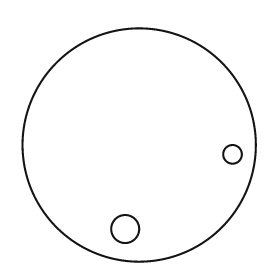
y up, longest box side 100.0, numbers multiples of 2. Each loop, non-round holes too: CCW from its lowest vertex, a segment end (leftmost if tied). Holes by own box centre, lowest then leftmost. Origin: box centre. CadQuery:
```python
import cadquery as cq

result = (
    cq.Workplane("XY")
    .moveTo(0.0, 0.0)
    .circle(50.0)
    .moveTo(-6.0, -36.0)
    .circle(6.0)
    .moveTo(40.0, -4.0)
    .circle(4.0)
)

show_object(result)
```